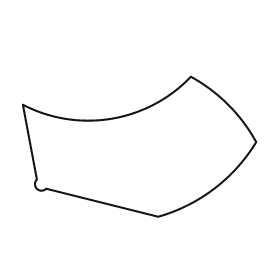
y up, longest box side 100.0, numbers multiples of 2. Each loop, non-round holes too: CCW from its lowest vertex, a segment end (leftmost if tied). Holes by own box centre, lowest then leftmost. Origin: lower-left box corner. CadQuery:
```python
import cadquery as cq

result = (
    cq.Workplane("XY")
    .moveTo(58.0, 0.0)
    .threePointArc((82.0, 12.0), (100.0, 32.0))
    .threePointArc((88.0, 48.0), (72.0, 60.0))
    .threePointArc((38.0, 42.0), (0.0, 48.0))
    .lineTo(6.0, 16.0)
    .threePointArc((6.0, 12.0), (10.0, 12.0))
    .close()
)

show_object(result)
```